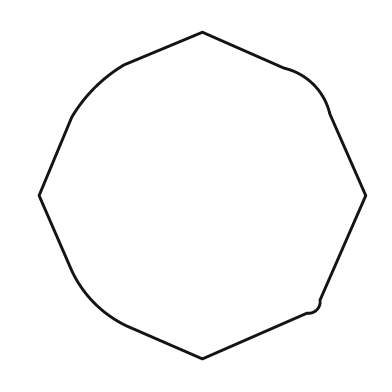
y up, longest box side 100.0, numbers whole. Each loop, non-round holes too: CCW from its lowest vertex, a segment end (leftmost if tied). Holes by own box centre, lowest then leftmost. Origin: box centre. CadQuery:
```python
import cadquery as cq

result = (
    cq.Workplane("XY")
    .moveTo(0.0, -50.0)
    .lineTo(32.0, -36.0)
    .threePointArc((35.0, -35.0), (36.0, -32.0))
    .lineTo(50.0, 0.0)
    .lineTo(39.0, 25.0)
    .threePointArc((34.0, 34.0), (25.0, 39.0))
    .lineTo(0.0, 50.0)
    .lineTo(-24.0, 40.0)
    .threePointArc((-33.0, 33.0), (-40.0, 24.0))
    .lineTo(-50.0, 0.0)
    .lineTo(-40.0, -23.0)
    .threePointArc((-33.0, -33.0), (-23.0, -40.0))
    .close()
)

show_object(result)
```